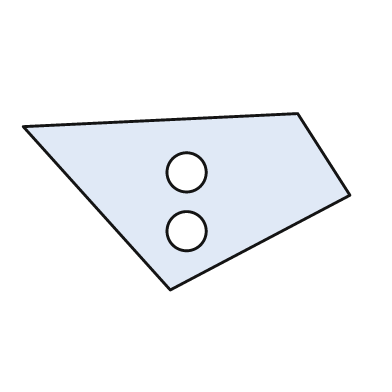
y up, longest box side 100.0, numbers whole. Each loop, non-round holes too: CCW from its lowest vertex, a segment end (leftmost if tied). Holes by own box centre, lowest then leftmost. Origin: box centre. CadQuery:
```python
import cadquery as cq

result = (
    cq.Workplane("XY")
    .moveTo(-5.0, -27.0)
    .lineTo(50.0, 2.0)
    .lineTo(34.0, 27.0)
    .lineTo(-50.0, 23.0)
    .close()
    .moveTo(0.0, -9.0)
    .circle(6.0)
    .moveTo(0.0, 9.0)
    .circle(6.0)
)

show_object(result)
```